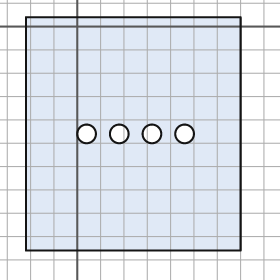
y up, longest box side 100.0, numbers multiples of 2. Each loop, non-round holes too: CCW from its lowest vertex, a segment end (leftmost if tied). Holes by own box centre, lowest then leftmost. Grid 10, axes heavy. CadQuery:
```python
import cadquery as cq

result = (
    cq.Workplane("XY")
    .moveTo(-22.0, -96.0)
    .lineTo(70.0, -96.0)
    .lineTo(70.0, 4.0)
    .lineTo(-22.0, 4.0)
    .close()
    .moveTo(4.0, -46.0)
    .circle(4.0)
    .moveTo(18.0, -46.0)
    .circle(4.0)
    .moveTo(32.0, -46.0)
    .circle(4.0)
    .moveTo(46.0, -46.0)
    .circle(4.0)
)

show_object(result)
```